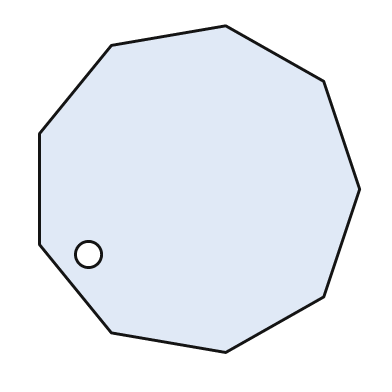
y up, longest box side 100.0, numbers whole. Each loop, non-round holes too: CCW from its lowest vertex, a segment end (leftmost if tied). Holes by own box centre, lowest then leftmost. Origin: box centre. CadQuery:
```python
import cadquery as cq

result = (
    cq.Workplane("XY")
    .moveTo(8.0, -50.0)
    .lineTo(38.0, -33.0)
    .lineTo(49.0, 0.0)
    .lineTo(38.0, 33.0)
    .lineTo(8.0, 50.0)
    .lineTo(-27.0, 44.0)
    .lineTo(-49.0, 17.0)
    .lineTo(-49.0, -17.0)
    .lineTo(-27.0, -44.0)
    .close()
    .moveTo(-34.0, -20.0)
    .circle(4.0)
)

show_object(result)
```